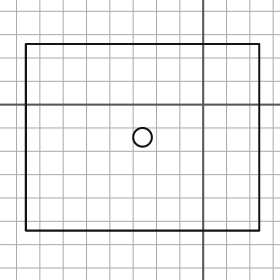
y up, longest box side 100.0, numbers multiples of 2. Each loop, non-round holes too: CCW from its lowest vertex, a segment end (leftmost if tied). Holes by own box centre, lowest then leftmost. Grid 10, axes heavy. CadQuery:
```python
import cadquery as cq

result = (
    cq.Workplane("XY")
    .moveTo(-76.0, -54.0)
    .lineTo(24.0, -54.0)
    .lineTo(24.0, 26.0)
    .lineTo(-76.0, 26.0)
    .close()
    .moveTo(-26.0, -14.0)
    .circle(4.0)
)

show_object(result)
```